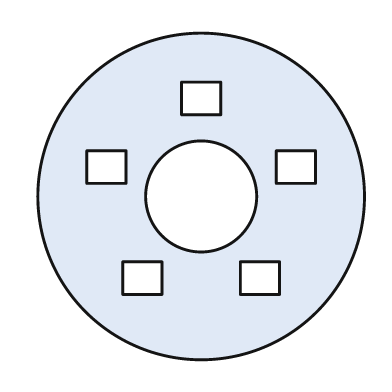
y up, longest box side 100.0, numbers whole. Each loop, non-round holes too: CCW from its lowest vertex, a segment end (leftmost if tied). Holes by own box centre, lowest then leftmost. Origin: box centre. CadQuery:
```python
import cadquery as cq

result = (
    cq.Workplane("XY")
    .moveTo(0.0, 0.0)
    .circle(50.0)
    .moveTo(-24.0, -30.0)
    .lineTo(-12.0, -30.0)
    .lineTo(-12.0, -20.0)
    .lineTo(-24.0, -20.0)
    .close()
    .moveTo(12.0, -30.0)
    .lineTo(24.0, -30.0)
    .lineTo(24.0, -20.0)
    .lineTo(12.0, -20.0)
    .close()
    .moveTo(0.0, 0.0)
    .circle(17.0)
    .moveTo(-35.0, 4.0)
    .lineTo(-23.0, 4.0)
    .lineTo(-23.0, 14.0)
    .lineTo(-35.0, 14.0)
    .close()
    .moveTo(23.0, 4.0)
    .lineTo(35.0, 4.0)
    .lineTo(35.0, 14.0)
    .lineTo(23.0, 14.0)
    .close()
    .moveTo(-6.0, 25.0)
    .lineTo(6.0, 25.0)
    .lineTo(6.0, 35.0)
    .lineTo(-6.0, 35.0)
    .close()
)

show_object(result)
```